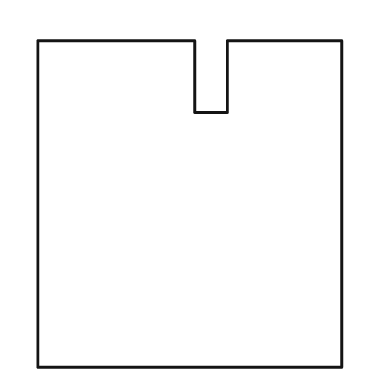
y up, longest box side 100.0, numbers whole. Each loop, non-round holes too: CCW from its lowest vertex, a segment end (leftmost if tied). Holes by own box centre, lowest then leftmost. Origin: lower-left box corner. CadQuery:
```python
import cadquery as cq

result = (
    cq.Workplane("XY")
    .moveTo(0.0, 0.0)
    .lineTo(93.0, 0.0)
    .lineTo(93.0, 100.0)
    .lineTo(58.0, 100.0)
    .lineTo(58.0, 78.0)
    .lineTo(48.0, 78.0)
    .lineTo(48.0, 100.0)
    .lineTo(0.0, 100.0)
    .close()
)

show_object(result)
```